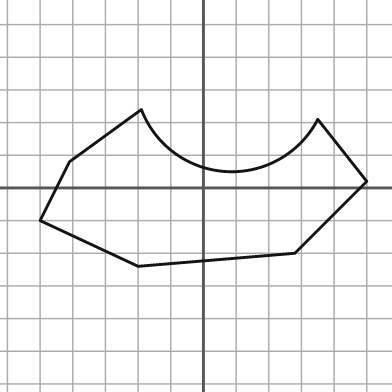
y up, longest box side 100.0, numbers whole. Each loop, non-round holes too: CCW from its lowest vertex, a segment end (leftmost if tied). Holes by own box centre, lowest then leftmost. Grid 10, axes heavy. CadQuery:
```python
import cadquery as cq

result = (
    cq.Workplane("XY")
    .moveTo(-20.0, -24.0)
    .lineTo(28.0, -20.0)
    .lineTo(50.0, 2.0)
    .lineTo(35.0, 21.0)
    .threePointArc((7.0, 5.0), (-19.0, 24.0))
    .lineTo(-41.0, 8.0)
    .lineTo(-50.0, -10.0)
    .close()
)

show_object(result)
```